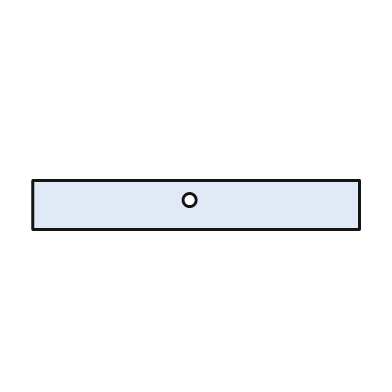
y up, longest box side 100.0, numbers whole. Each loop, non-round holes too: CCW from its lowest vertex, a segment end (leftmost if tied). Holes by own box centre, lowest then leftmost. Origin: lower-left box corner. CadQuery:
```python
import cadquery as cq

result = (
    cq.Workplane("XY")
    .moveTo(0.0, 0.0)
    .lineTo(100.0, 0.0)
    .lineTo(100.0, 15.0)
    .lineTo(0.0, 15.0)
    .close()
    .moveTo(48.0, 9.0)
    .circle(2.0)
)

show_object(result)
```